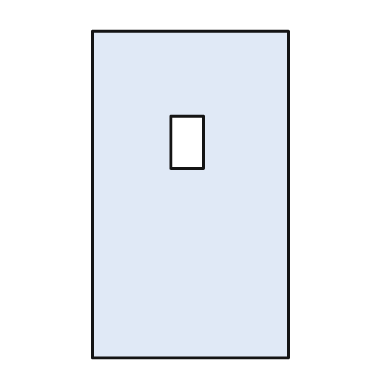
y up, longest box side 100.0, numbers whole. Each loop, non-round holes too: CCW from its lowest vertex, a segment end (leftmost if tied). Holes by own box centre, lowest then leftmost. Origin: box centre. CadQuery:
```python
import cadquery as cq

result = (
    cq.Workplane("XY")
    .moveTo(-30.0, -50.0)
    .lineTo(30.0, -50.0)
    .lineTo(30.0, 50.0)
    .lineTo(-30.0, 50.0)
    .close()
    .moveTo(-6.0, 8.0)
    .lineTo(4.0, 8.0)
    .lineTo(4.0, 24.0)
    .lineTo(-6.0, 24.0)
    .close()
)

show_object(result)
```